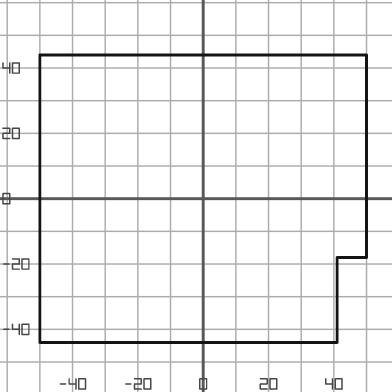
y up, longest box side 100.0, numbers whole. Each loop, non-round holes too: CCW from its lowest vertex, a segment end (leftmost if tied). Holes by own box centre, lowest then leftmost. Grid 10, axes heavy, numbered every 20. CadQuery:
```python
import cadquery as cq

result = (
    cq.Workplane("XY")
    .moveTo(-50.0, -44.0)
    .lineTo(41.0, -44.0)
    .lineTo(41.0, -18.0)
    .lineTo(50.0, -18.0)
    .lineTo(50.0, 44.0)
    .lineTo(-50.0, 44.0)
    .close()
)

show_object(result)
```